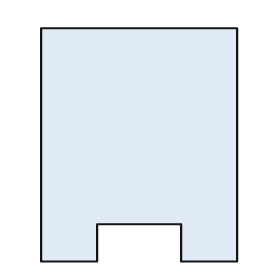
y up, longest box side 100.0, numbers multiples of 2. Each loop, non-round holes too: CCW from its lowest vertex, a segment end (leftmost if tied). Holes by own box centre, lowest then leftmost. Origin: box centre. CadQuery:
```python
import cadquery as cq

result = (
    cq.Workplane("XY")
    .moveTo(-42.0, -50.0)
    .lineTo(-18.0, -50.0)
    .lineTo(-18.0, -34.0)
    .lineTo(18.0, -34.0)
    .lineTo(18.0, -50.0)
    .lineTo(42.0, -50.0)
    .lineTo(42.0, 50.0)
    .lineTo(-42.0, 50.0)
    .close()
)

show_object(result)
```